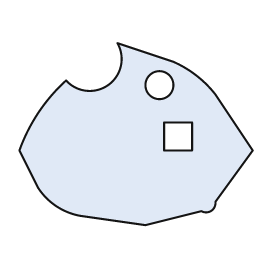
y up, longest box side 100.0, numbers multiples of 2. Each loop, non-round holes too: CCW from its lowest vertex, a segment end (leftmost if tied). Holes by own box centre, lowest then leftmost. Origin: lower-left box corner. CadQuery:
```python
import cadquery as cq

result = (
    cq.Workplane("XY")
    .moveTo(54.0, 0.0)
    .lineTo(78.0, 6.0)
    .threePointArc((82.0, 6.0), (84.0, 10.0))
    .lineTo(100.0, 32.0)
    .lineTo(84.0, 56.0)
    .threePointArc((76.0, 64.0), (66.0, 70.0))
    .lineTo(42.0, 78.0)
    .threePointArc((38.0, 60.0), (20.0, 62.0))
    .threePointArc((8.0, 48.0), (0.0, 32.0))
    .lineTo(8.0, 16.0)
    .threePointArc((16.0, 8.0), (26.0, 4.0))
    .close()
    .moveTo(62.0, 32.0)
    .lineTo(74.0, 32.0)
    .lineTo(74.0, 44.0)
    .lineTo(62.0, 44.0)
    .close()
    .moveTo(60.0, 60.0)
    .circle(6.0)
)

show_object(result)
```